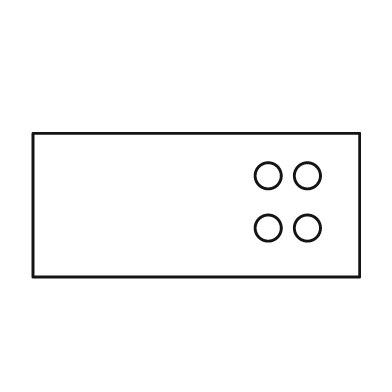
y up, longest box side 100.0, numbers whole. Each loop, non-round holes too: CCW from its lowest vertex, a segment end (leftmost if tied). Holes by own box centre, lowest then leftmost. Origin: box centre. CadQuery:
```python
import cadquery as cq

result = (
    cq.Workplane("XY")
    .moveTo(-50.0, -22.0)
    .lineTo(50.0, -22.0)
    .lineTo(50.0, 22.0)
    .lineTo(-50.0, 22.0)
    .close()
    .moveTo(22.0, -7.0)
    .circle(4.0)
    .moveTo(34.0, -7.0)
    .circle(4.0)
    .moveTo(22.0, 9.0)
    .circle(4.0)
    .moveTo(34.0, 9.0)
    .circle(4.0)
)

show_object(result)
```